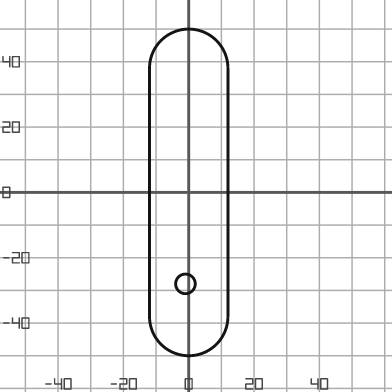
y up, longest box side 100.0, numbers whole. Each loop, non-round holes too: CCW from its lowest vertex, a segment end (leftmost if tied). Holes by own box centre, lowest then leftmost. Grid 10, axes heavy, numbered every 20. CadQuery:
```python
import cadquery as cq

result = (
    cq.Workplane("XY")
    .moveTo(-12.0, -38.0)
    .threePointArc((0.0, -50.0), (12.0, -38.0))
    .lineTo(12.0, 38.0)
    .threePointArc((0.0, 50.0), (-12.0, 38.0))
    .close()
    .moveTo(-1.0, -28.0)
    .circle(3.0)
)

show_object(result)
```